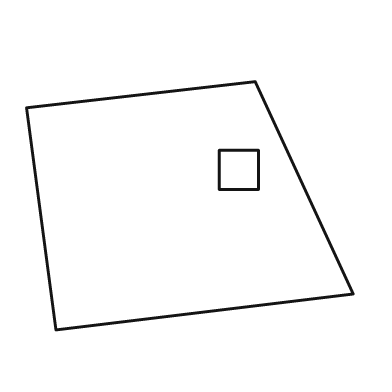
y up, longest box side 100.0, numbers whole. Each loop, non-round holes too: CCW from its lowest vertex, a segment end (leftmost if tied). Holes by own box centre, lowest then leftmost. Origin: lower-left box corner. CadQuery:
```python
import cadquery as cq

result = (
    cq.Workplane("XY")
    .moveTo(9.0, 0.0)
    .lineTo(100.0, 11.0)
    .lineTo(70.0, 76.0)
    .lineTo(0.0, 68.0)
    .close()
    .moveTo(59.0, 43.0)
    .lineTo(71.0, 43.0)
    .lineTo(71.0, 55.0)
    .lineTo(59.0, 55.0)
    .close()
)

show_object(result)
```